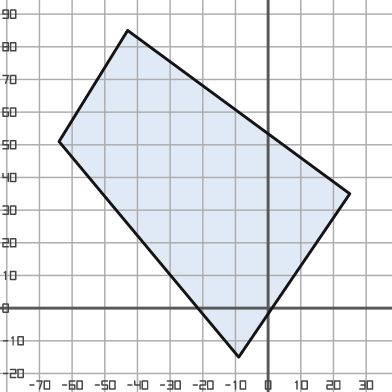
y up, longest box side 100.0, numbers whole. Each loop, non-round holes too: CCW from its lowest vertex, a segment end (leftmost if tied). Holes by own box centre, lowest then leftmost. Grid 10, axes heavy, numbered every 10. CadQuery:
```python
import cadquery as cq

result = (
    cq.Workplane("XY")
    .moveTo(-9.0, -15.0)
    .lineTo(25.0, 35.0)
    .lineTo(-43.0, 85.0)
    .lineTo(-64.0, 51.0)
    .close()
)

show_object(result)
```